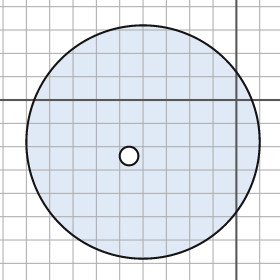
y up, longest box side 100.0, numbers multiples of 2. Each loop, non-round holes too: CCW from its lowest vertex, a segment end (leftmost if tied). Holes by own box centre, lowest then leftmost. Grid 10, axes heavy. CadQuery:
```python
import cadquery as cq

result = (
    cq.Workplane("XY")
    .moveTo(-40.0, -18.0)
    .circle(50.0)
    .moveTo(-46.0, -24.0)
    .circle(4.0)
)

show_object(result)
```